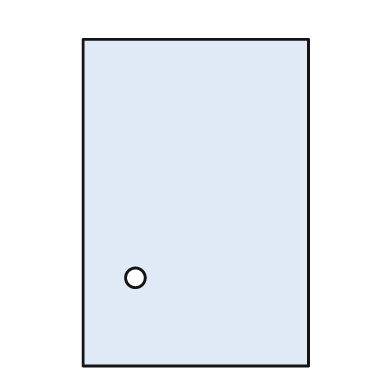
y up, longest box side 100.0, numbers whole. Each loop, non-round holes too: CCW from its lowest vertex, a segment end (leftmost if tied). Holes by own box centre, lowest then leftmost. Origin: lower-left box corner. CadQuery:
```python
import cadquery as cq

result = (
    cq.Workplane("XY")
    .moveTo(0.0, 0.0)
    .lineTo(69.0, 0.0)
    .lineTo(69.0, 100.0)
    .lineTo(0.0, 100.0)
    .close()
    .moveTo(16.0, 27.0)
    .circle(3.0)
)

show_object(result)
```